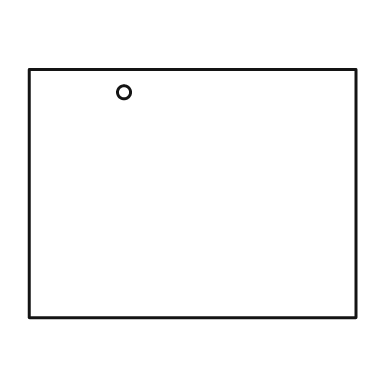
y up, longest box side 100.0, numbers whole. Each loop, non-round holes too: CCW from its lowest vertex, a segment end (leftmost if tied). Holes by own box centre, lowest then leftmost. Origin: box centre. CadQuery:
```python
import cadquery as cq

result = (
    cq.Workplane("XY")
    .moveTo(-50.0, -38.0)
    .lineTo(50.0, -38.0)
    .lineTo(50.0, 38.0)
    .lineTo(-50.0, 38.0)
    .close()
    .moveTo(-21.0, 31.0)
    .circle(2.0)
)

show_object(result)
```